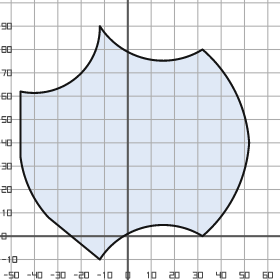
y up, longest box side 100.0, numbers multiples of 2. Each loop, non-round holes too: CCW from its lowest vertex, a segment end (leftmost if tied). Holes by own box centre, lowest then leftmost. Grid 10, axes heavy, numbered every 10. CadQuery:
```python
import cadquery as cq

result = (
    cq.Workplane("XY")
    .moveTo(-12.0, -10.0)
    .threePointArc((8.0, 4.0), (32.0, 0.0))
    .threePointArc((46.0, 18.0), (52.0, 40.0))
    .threePointArc((46.0, 62.0), (32.0, 80.0))
    .threePointArc((8.0, 76.0), (-12.0, 90.0))
    .threePointArc((-22.0, 68.0), (-46.0, 62.0))
    .lineTo(-46.0, 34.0)
    .threePointArc((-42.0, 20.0), (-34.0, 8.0))
    .close()
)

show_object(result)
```